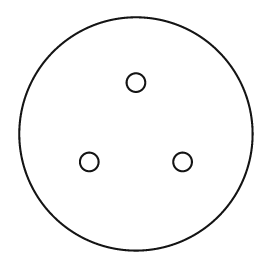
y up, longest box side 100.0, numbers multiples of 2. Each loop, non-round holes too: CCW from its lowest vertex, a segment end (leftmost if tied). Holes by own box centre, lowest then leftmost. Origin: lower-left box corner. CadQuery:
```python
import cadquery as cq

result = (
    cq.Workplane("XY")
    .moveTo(50.0, 50.0)
    .circle(50.0)
    .moveTo(30.0, 38.0)
    .circle(4.0)
    .moveTo(70.0, 38.0)
    .circle(4.0)
    .moveTo(50.0, 72.0)
    .circle(4.0)
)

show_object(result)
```